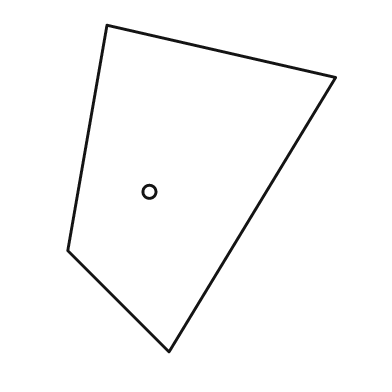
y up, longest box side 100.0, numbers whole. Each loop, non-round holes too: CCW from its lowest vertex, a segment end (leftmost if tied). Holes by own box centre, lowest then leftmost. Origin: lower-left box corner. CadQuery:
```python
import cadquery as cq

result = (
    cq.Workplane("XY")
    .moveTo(31.0, 0.0)
    .lineTo(82.0, 84.0)
    .lineTo(12.0, 100.0)
    .lineTo(0.0, 31.0)
    .close()
    .moveTo(25.0, 49.0)
    .circle(2.0)
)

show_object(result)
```